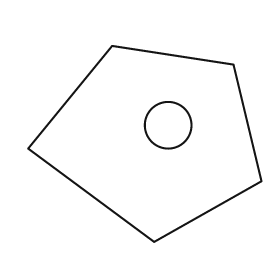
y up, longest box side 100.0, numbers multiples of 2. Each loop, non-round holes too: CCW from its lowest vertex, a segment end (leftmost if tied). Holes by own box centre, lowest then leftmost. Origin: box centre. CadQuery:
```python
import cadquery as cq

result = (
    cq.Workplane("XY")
    .moveTo(4.0, -42.0)
    .lineTo(50.0, -16.0)
    .lineTo(38.0, 34.0)
    .lineTo(-14.0, 42.0)
    .lineTo(-50.0, -2.0)
    .close()
    .moveTo(10.0, 8.0)
    .circle(10.0)
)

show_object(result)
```